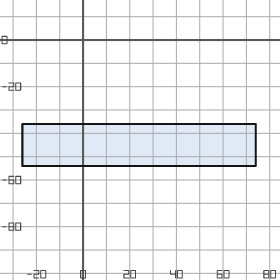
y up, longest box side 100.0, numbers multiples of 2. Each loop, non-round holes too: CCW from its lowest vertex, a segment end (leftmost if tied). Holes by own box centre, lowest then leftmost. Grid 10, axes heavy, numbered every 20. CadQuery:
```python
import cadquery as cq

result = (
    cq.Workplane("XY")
    .moveTo(-26.0, -54.0)
    .lineTo(74.0, -54.0)
    .lineTo(74.0, -36.0)
    .lineTo(-26.0, -36.0)
    .close()
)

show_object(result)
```